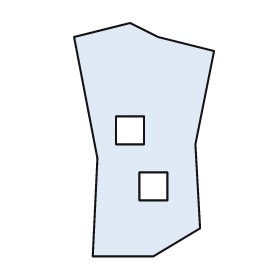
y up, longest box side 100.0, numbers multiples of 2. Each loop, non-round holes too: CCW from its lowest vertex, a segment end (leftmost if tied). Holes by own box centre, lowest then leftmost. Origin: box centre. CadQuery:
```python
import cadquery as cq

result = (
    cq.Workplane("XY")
    .moveTo(-22.0, -50.0)
    .lineTo(4.0, -50.0)
    .lineTo(24.0, -38.0)
    .lineTo(22.0, -2.0)
    .lineTo(30.0, 38.0)
    .lineTo(6.0, 44.0)
    .lineTo(-6.0, 50.0)
    .lineTo(-30.0, 44.0)
    .lineTo(-20.0, -8.0)
    .close()
    .moveTo(-2.0, -26.0)
    .lineTo(10.0, -26.0)
    .lineTo(10.0, -14.0)
    .lineTo(-2.0, -14.0)
    .close()
    .moveTo(-12.0, -2.0)
    .lineTo(0.0, -2.0)
    .lineTo(0.0, 10.0)
    .lineTo(-12.0, 10.0)
    .close()
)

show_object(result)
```